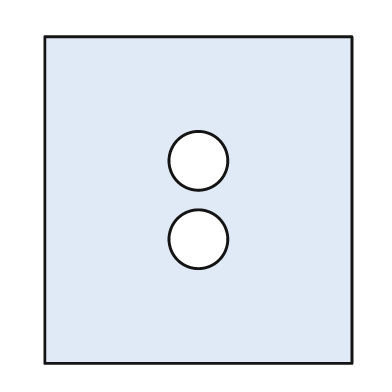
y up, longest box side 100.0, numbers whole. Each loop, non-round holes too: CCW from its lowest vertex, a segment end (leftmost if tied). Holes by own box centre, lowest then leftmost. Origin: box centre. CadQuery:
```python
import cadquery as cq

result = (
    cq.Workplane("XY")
    .moveTo(-47.0, -50.0)
    .lineTo(47.0, -50.0)
    .lineTo(47.0, 50.0)
    .lineTo(-47.0, 50.0)
    .close()
    .moveTo(0.0, -12.0)
    .circle(9.0)
    .moveTo(0.0, 12.0)
    .circle(9.0)
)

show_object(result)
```